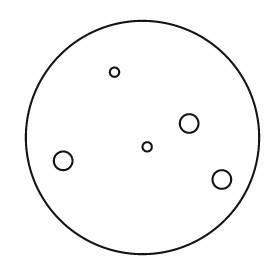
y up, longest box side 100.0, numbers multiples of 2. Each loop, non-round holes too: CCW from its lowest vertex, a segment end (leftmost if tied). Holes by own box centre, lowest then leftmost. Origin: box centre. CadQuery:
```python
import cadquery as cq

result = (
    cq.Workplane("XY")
    .moveTo(0.0, 0.0)
    .circle(50.0)
    .moveTo(34.0, -18.0)
    .circle(4.0)
    .moveTo(-34.0, -10.0)
    .circle(4.0)
    .moveTo(2.0, -4.0)
    .circle(2.0)
    .moveTo(20.0, 6.0)
    .circle(4.0)
    .moveTo(-12.0, 28.0)
    .circle(2.0)
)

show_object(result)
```